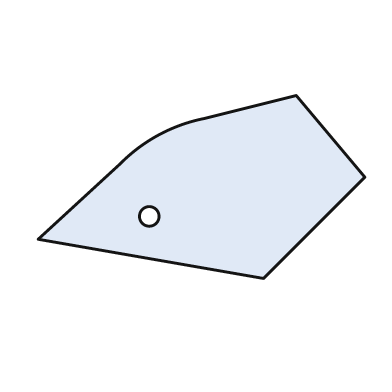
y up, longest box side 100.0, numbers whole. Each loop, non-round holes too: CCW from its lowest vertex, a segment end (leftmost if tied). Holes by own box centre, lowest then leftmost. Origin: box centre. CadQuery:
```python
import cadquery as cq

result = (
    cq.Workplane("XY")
    .moveTo(19.0, -28.0)
    .lineTo(50.0, 3.0)
    .lineTo(29.0, 28.0)
    .lineTo(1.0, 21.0)
    .threePointArc((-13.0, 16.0), (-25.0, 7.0))
    .lineTo(-50.0, -16.0)
    .close()
    .moveTo(-16.0, -9.0)
    .circle(3.0)
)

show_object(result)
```